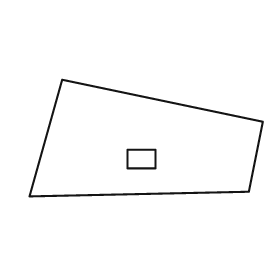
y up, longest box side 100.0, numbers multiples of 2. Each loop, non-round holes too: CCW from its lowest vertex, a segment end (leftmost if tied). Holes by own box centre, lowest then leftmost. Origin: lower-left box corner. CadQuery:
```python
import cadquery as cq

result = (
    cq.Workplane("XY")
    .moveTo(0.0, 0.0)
    .lineTo(94.0, 2.0)
    .lineTo(100.0, 32.0)
    .lineTo(14.0, 50.0)
    .close()
    .moveTo(42.0, 12.0)
    .lineTo(54.0, 12.0)
    .lineTo(54.0, 20.0)
    .lineTo(42.0, 20.0)
    .close()
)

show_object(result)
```